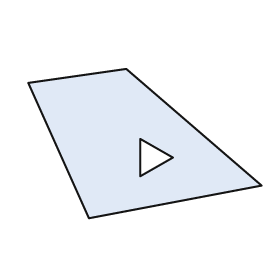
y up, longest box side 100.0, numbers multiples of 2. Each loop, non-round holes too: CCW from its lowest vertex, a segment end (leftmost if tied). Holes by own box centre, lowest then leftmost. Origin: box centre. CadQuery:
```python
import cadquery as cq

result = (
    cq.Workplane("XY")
    .moveTo(-24.0, -32.0)
    .lineTo(50.0, -18.0)
    .lineTo(-8.0, 32.0)
    .lineTo(-50.0, 26.0)
    .close()
    .moveTo(-2.0, -14.0)
    .lineTo(12.0, -6.0)
    .lineTo(-2.0, 2.0)
    .close()
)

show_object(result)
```